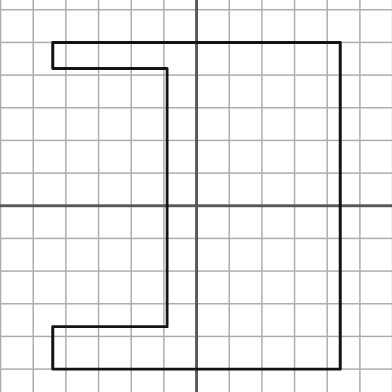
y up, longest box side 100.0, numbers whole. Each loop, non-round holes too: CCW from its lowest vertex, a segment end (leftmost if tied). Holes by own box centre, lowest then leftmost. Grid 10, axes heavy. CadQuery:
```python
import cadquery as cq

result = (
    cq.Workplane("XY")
    .moveTo(-44.0, -50.0)
    .lineTo(44.0, -50.0)
    .lineTo(44.0, 50.0)
    .lineTo(-44.0, 50.0)
    .lineTo(-44.0, 42.0)
    .lineTo(-9.0, 42.0)
    .lineTo(-9.0, -37.0)
    .lineTo(-44.0, -37.0)
    .close()
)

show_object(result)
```